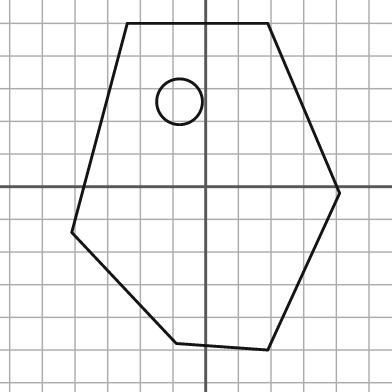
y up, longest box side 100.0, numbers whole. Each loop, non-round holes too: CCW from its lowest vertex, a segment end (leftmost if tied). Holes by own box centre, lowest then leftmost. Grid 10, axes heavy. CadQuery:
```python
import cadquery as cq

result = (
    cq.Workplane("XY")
    .moveTo(19.0, -50.0)
    .lineTo(41.0, -2.0)
    .lineTo(19.0, 50.0)
    .lineTo(-24.0, 50.0)
    .lineTo(-41.0, -14.0)
    .lineTo(-9.0, -48.0)
    .close()
    .moveTo(-8.0, 26.0)
    .circle(7.0)
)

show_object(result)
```